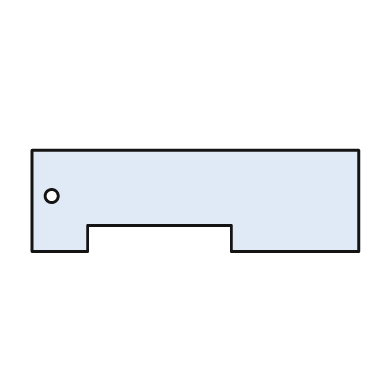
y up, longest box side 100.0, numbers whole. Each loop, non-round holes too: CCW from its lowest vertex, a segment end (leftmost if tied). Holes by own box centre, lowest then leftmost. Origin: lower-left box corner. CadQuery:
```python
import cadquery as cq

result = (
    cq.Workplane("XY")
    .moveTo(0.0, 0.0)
    .lineTo(17.0, 0.0)
    .lineTo(17.0, 8.0)
    .lineTo(61.0, 8.0)
    .lineTo(61.0, 0.0)
    .lineTo(100.0, 0.0)
    .lineTo(100.0, 31.0)
    .lineTo(0.0, 31.0)
    .close()
    .moveTo(6.0, 17.0)
    .circle(2.0)
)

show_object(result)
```